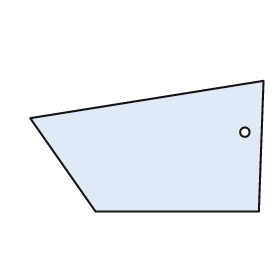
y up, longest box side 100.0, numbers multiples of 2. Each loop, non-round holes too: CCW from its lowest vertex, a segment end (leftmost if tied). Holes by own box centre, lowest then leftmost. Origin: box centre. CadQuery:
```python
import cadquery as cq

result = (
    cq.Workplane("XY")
    .moveTo(-22.0, -28.0)
    .lineTo(48.0, -28.0)
    .lineTo(50.0, 28.0)
    .lineTo(-50.0, 12.0)
    .close()
    .moveTo(42.0, 6.0)
    .circle(2.0)
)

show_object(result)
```